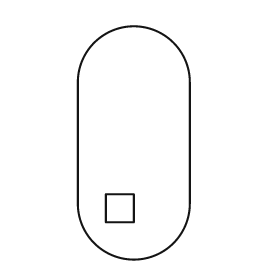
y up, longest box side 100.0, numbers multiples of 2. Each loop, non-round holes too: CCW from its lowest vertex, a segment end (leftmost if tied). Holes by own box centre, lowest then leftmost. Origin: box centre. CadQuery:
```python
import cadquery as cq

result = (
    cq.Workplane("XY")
    .moveTo(-24.0, -26.0)
    .threePointArc((0.0, -50.0), (24.0, -26.0))
    .lineTo(24.0, 26.0)
    .threePointArc((0.0, 50.0), (-24.0, 26.0))
    .close()
    .moveTo(-12.0, -34.0)
    .lineTo(0.0, -34.0)
    .lineTo(0.0, -22.0)
    .lineTo(-12.0, -22.0)
    .close()
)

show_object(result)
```